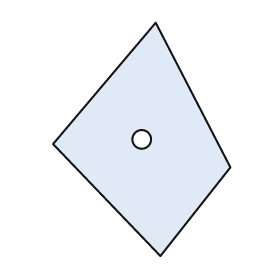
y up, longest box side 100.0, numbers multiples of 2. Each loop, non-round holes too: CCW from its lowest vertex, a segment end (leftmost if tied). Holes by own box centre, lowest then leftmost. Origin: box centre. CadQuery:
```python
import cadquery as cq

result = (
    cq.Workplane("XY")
    .moveTo(8.0, -50.0)
    .lineTo(38.0, -12.0)
    .lineTo(6.0, 50.0)
    .lineTo(-38.0, -2.0)
    .close()
    .moveTo(0.0, 0.0)
    .circle(4.0)
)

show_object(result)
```